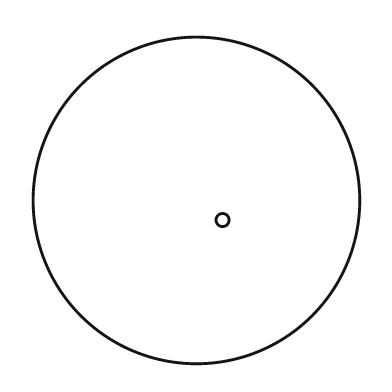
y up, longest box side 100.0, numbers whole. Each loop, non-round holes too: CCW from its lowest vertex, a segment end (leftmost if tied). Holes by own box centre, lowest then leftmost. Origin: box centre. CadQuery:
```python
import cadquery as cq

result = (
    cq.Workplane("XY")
    .moveTo(0.0, 0.0)
    .circle(50.0)
    .moveTo(8.0, -6.0)
    .circle(2.0)
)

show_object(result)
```